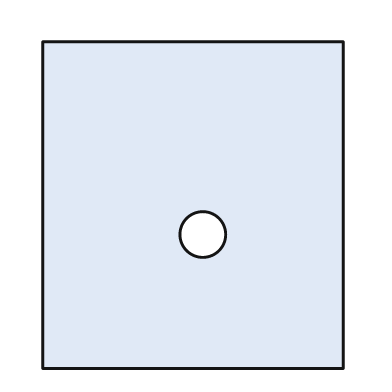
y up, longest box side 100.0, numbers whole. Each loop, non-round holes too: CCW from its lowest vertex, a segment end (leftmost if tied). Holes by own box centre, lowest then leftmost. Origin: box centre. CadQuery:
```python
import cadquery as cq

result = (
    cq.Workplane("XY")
    .moveTo(-46.0, -50.0)
    .lineTo(46.0, -50.0)
    .lineTo(46.0, 50.0)
    .lineTo(-46.0, 50.0)
    .close()
    .moveTo(3.0, -9.0)
    .circle(7.0)
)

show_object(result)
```